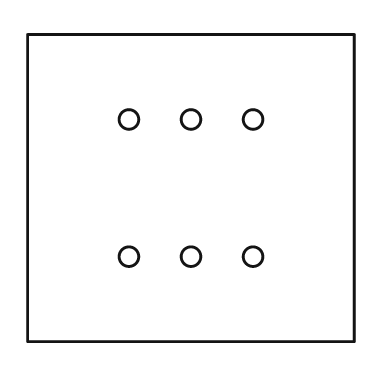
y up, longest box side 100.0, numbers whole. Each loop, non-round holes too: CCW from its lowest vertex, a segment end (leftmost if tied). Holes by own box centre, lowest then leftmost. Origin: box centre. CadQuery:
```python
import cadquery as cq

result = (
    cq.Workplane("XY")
    .moveTo(-50.0, -47.0)
    .lineTo(50.0, -47.0)
    .lineTo(50.0, 47.0)
    .lineTo(-50.0, 47.0)
    .close()
    .moveTo(-19.0, -21.0)
    .circle(3.0)
    .moveTo(0.0, -21.0)
    .circle(3.0)
    .moveTo(19.0, -21.0)
    .circle(3.0)
    .moveTo(-19.0, 21.0)
    .circle(3.0)
    .moveTo(0.0, 21.0)
    .circle(3.0)
    .moveTo(19.0, 21.0)
    .circle(3.0)
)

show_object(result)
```